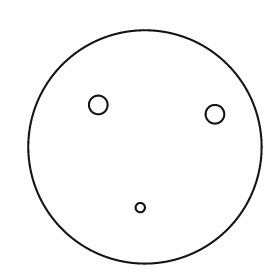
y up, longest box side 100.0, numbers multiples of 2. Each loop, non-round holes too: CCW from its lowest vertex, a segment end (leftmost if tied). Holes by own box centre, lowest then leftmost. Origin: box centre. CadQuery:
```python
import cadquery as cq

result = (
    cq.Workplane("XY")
    .moveTo(0.0, 0.0)
    .circle(50.0)
    .moveTo(-2.0, -26.0)
    .circle(2.0)
    .moveTo(30.0, 14.0)
    .circle(4.0)
    .moveTo(-20.0, 18.0)
    .circle(4.0)
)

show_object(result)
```